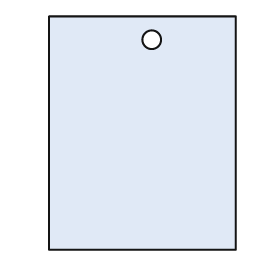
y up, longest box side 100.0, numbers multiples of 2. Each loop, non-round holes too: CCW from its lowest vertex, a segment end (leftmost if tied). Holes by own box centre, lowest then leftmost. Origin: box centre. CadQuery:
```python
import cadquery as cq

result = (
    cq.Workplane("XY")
    .moveTo(-40.0, -50.0)
    .lineTo(40.0, -50.0)
    .lineTo(40.0, 50.0)
    .lineTo(-40.0, 50.0)
    .close()
    .moveTo(4.0, 40.0)
    .circle(4.0)
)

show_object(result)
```